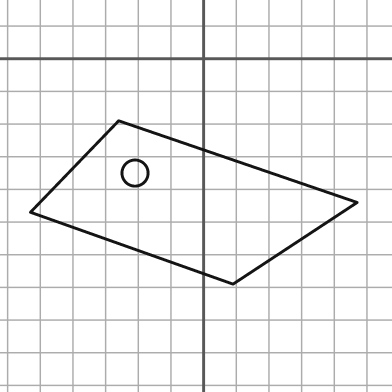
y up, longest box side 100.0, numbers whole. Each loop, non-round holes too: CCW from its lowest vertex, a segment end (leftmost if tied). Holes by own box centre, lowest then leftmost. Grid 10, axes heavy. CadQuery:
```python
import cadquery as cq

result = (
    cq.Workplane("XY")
    .moveTo(9.0, -69.0)
    .lineTo(47.0, -44.0)
    .lineTo(-26.0, -19.0)
    .lineTo(-53.0, -47.0)
    .close()
    .moveTo(-21.0, -35.0)
    .circle(4.0)
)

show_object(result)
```